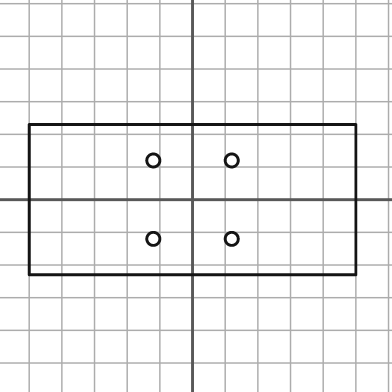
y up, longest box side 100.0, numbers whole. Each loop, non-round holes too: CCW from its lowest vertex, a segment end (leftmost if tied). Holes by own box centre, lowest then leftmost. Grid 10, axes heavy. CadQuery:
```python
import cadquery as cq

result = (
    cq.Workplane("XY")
    .moveTo(-50.0, -23.0)
    .lineTo(50.0, -23.0)
    .lineTo(50.0, 23.0)
    .lineTo(-50.0, 23.0)
    .close()
    .moveTo(-12.0, -12.0)
    .circle(2.0)
    .moveTo(12.0, -12.0)
    .circle(2.0)
    .moveTo(-12.0, 12.0)
    .circle(2.0)
    .moveTo(12.0, 12.0)
    .circle(2.0)
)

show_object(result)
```